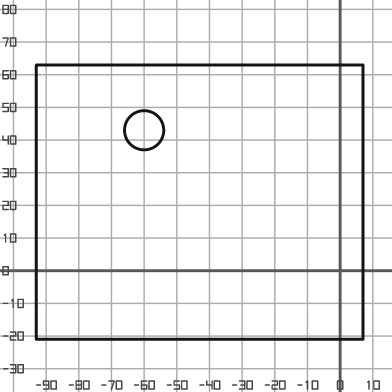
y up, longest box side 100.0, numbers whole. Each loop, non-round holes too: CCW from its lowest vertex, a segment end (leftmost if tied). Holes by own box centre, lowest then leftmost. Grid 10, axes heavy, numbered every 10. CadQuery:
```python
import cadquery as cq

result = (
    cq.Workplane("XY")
    .moveTo(-93.0, -21.0)
    .lineTo(7.0, -21.0)
    .lineTo(7.0, 63.0)
    .lineTo(-93.0, 63.0)
    .close()
    .moveTo(-60.0, 43.0)
    .circle(6.0)
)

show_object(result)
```